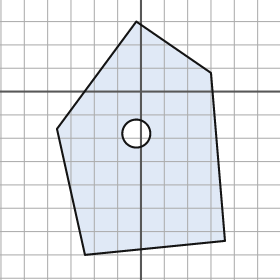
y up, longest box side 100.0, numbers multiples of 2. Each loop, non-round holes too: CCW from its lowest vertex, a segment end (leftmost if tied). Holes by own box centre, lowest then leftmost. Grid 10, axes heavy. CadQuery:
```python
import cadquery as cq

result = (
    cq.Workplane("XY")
    .moveTo(-24.0, -70.0)
    .lineTo(36.0, -64.0)
    .lineTo(30.0, 8.0)
    .lineTo(-2.0, 30.0)
    .lineTo(-36.0, -16.0)
    .close()
    .moveTo(-2.0, -18.0)
    .circle(6.0)
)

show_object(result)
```